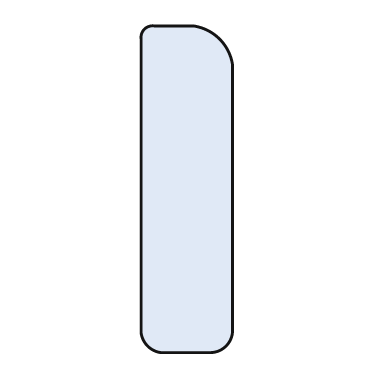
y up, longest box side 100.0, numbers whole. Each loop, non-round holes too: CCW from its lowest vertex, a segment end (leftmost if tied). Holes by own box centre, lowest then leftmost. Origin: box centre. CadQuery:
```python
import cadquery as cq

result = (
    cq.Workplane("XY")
    .moveTo(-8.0, -50.0)
    .lineTo(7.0, -50.0)
    .threePointArc((12.0, -48.0), (14.0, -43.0))
    .lineTo(14.0, 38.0)
    .threePointArc((10.0, 46.0), (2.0, 50.0))
    .lineTo(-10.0, 50.0)
    .threePointArc((-13.0, 49.0), (-14.0, 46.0))
    .lineTo(-14.0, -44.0)
    .threePointArc((-12.0, -48.0), (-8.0, -50.0))
    .close()
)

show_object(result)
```